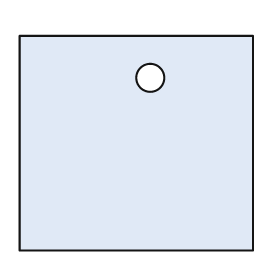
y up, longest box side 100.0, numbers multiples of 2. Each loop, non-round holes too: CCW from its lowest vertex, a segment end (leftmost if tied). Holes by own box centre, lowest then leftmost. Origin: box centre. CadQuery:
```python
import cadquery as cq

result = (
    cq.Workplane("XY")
    .moveTo(-50.0, -46.0)
    .lineTo(50.0, -46.0)
    .lineTo(50.0, 46.0)
    .lineTo(-50.0, 46.0)
    .close()
    .moveTo(6.0, 28.0)
    .circle(6.0)
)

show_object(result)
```